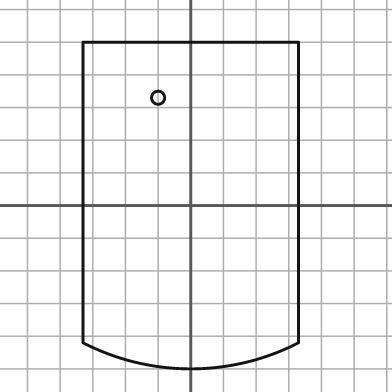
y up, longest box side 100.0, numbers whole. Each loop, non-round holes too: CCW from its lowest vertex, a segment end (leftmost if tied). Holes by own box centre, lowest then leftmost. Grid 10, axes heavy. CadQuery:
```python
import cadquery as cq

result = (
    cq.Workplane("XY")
    .moveTo(-33.0, -42.0)
    .threePointArc((0.0, -50.0), (33.0, -42.0))
    .lineTo(33.0, 50.0)
    .lineTo(-33.0, 50.0)
    .close()
    .moveTo(-10.0, 33.0)
    .circle(2.0)
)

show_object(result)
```